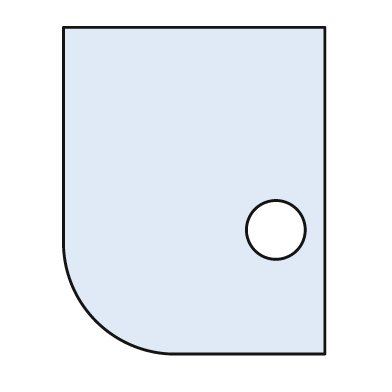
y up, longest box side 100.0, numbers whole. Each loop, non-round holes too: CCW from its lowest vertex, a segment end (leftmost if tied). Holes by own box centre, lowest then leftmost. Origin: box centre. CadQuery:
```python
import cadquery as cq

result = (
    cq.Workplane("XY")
    .moveTo(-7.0, -50.0)
    .lineTo(40.0, -50.0)
    .lineTo(40.0, 50.0)
    .lineTo(-40.0, 50.0)
    .lineTo(-40.0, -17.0)
    .threePointArc((-30.0, -40.0), (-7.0, -50.0))
    .close()
    .moveTo(25.0, -12.0)
    .circle(9.0)
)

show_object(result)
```